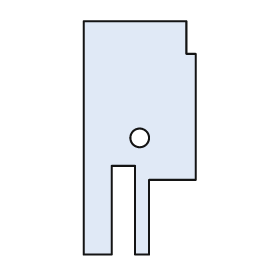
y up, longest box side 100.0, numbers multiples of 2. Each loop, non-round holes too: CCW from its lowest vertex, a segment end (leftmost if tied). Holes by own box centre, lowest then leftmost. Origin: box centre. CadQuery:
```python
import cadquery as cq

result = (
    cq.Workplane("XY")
    .moveTo(-24.0, -50.0)
    .lineTo(-12.0, -50.0)
    .lineTo(-12.0, -12.0)
    .lineTo(-2.0, -12.0)
    .lineTo(-2.0, -50.0)
    .lineTo(4.0, -50.0)
    .lineTo(4.0, -18.0)
    .lineTo(24.0, -18.0)
    .lineTo(24.0, 36.0)
    .lineTo(20.0, 36.0)
    .lineTo(20.0, 50.0)
    .lineTo(-24.0, 50.0)
    .close()
    .moveTo(0.0, 0.0)
    .circle(4.0)
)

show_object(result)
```